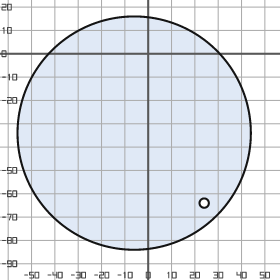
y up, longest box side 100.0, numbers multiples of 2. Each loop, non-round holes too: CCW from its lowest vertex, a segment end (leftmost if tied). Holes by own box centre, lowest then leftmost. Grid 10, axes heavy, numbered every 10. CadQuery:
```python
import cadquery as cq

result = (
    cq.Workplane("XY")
    .moveTo(-6.0, -34.0)
    .circle(50.0)
    .moveTo(24.0, -64.0)
    .circle(2.0)
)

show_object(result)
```